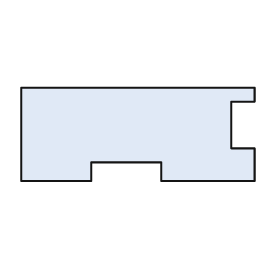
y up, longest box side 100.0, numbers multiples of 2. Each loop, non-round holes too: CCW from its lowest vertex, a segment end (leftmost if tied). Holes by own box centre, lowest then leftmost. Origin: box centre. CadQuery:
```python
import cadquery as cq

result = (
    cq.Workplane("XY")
    .moveTo(-50.0, -20.0)
    .lineTo(-20.0, -20.0)
    .lineTo(-20.0, -12.0)
    .lineTo(10.0, -12.0)
    .lineTo(10.0, -20.0)
    .lineTo(50.0, -20.0)
    .lineTo(50.0, -6.0)
    .lineTo(40.0, -6.0)
    .lineTo(40.0, 14.0)
    .lineTo(50.0, 14.0)
    .lineTo(50.0, 20.0)
    .lineTo(-50.0, 20.0)
    .close()
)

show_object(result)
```